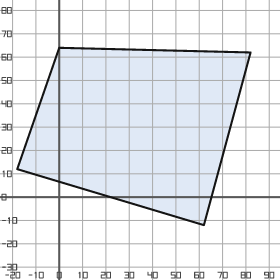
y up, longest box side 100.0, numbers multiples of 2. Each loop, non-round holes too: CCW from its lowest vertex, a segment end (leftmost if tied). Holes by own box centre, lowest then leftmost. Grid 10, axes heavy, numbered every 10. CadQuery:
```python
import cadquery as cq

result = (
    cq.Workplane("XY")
    .moveTo(62.0, -12.0)
    .lineTo(82.0, 62.0)
    .lineTo(0.0, 64.0)
    .lineTo(-18.0, 12.0)
    .close()
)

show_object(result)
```